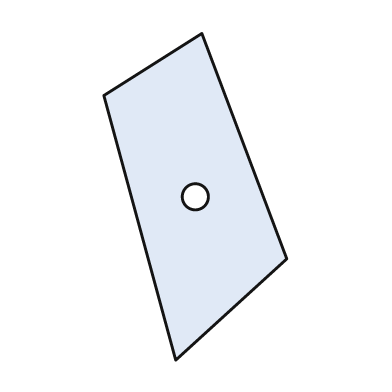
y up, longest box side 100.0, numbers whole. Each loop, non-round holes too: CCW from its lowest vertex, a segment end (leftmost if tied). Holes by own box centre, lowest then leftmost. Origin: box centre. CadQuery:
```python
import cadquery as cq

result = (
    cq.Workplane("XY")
    .moveTo(-6.0, -50.0)
    .lineTo(28.0, -19.0)
    .lineTo(2.0, 50.0)
    .lineTo(-28.0, 31.0)
    .close()
    .moveTo(0.0, 0.0)
    .circle(4.0)
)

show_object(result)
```